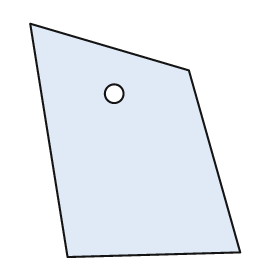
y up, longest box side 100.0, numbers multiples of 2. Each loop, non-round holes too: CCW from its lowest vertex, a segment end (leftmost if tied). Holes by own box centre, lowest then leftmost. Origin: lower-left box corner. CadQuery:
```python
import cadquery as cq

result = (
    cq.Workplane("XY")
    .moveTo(16.0, 0.0)
    .lineTo(90.0, 2.0)
    .lineTo(68.0, 80.0)
    .lineTo(0.0, 100.0)
    .close()
    .moveTo(36.0, 70.0)
    .circle(4.0)
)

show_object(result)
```